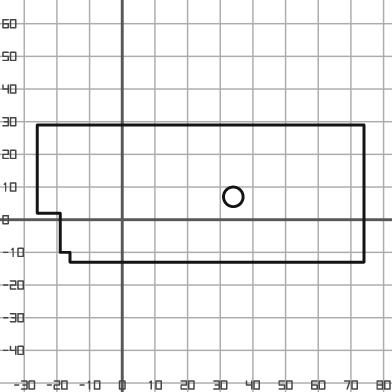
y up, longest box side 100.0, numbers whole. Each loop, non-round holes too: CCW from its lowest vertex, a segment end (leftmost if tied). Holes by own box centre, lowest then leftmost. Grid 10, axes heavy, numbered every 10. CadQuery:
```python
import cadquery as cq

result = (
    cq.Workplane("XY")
    .moveTo(-16.0, -13.0)
    .lineTo(74.0, -13.0)
    .lineTo(74.0, 29.0)
    .lineTo(-26.0, 29.0)
    .lineTo(-26.0, 2.0)
    .lineTo(-19.0, 2.0)
    .lineTo(-19.0, -10.0)
    .lineTo(-16.0, -10.0)
    .close()
    .moveTo(34.0, 7.0)
    .circle(3.0)
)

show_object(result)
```